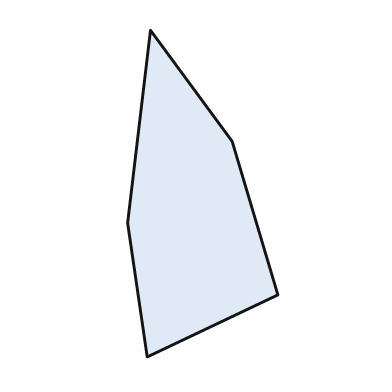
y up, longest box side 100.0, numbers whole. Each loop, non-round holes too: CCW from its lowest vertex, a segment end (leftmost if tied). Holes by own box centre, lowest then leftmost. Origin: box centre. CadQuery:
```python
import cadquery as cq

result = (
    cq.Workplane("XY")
    .moveTo(-17.0, -50.0)
    .lineTo(23.0, -31.0)
    .lineTo(9.0, 16.0)
    .lineTo(-16.0, 50.0)
    .lineTo(-23.0, -9.0)
    .close()
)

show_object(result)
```